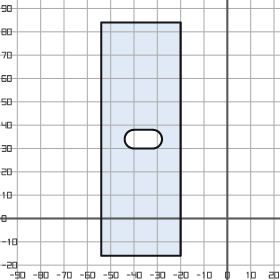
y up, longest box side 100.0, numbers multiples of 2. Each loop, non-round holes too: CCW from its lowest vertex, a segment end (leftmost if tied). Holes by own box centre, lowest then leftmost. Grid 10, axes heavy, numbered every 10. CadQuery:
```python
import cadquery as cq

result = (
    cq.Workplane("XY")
    .moveTo(-54.0, -16.0)
    .lineTo(-20.0, -16.0)
    .lineTo(-20.0, 84.0)
    .lineTo(-54.0, 84.0)
    .close()
    .moveTo(-40.0, 30.0)
    .lineTo(-32.0, 30.0)
    .threePointArc((-28.0, 34.0), (-32.0, 38.0))
    .lineTo(-40.0, 38.0)
    .threePointArc((-44.0, 34.0), (-40.0, 30.0))
    .close()
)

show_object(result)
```